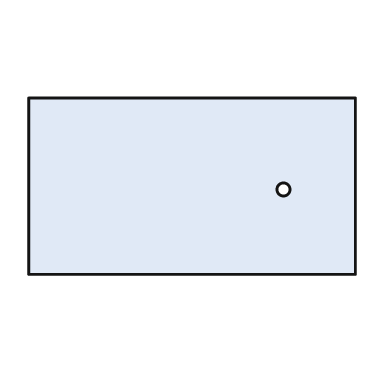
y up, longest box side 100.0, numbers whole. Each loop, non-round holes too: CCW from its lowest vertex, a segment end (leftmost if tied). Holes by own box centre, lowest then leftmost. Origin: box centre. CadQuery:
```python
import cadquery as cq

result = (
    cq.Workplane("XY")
    .moveTo(-50.0, -27.0)
    .lineTo(50.0, -27.0)
    .lineTo(50.0, 27.0)
    .lineTo(-50.0, 27.0)
    .close()
    .moveTo(28.0, -1.0)
    .circle(2.0)
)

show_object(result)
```